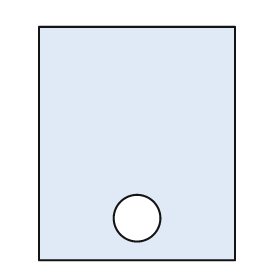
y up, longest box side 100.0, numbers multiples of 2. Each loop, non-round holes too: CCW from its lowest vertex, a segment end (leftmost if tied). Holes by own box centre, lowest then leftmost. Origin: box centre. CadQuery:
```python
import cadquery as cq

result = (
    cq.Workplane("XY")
    .moveTo(-42.0, -50.0)
    .lineTo(42.0, -50.0)
    .lineTo(42.0, 50.0)
    .lineTo(-42.0, 50.0)
    .close()
    .moveTo(0.0, -32.0)
    .circle(10.0)
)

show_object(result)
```